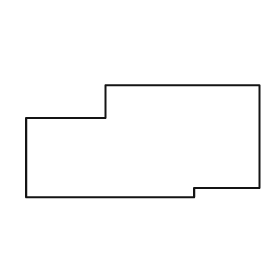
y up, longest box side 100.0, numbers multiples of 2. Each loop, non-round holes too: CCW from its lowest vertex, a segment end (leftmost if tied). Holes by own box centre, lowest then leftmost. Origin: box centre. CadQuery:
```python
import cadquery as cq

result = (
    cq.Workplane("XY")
    .moveTo(-50.0, -24.0)
    .lineTo(22.0, -24.0)
    .lineTo(22.0, -20.0)
    .lineTo(50.0, -20.0)
    .lineTo(50.0, 24.0)
    .lineTo(-16.0, 24.0)
    .lineTo(-16.0, 10.0)
    .lineTo(-50.0, 10.0)
    .close()
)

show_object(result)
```